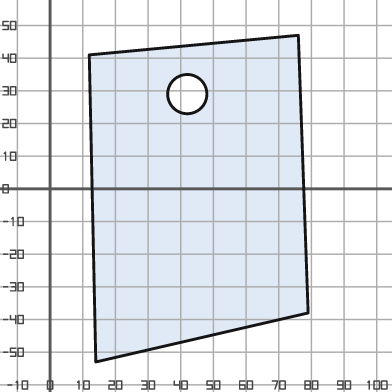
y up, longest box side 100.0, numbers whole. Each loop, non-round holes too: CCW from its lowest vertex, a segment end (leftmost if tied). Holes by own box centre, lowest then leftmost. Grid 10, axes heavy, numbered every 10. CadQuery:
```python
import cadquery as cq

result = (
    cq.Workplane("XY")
    .moveTo(14.0, -53.0)
    .lineTo(79.0, -38.0)
    .lineTo(76.0, 47.0)
    .lineTo(12.0, 41.0)
    .close()
    .moveTo(42.0, 29.0)
    .circle(6.0)
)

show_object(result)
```